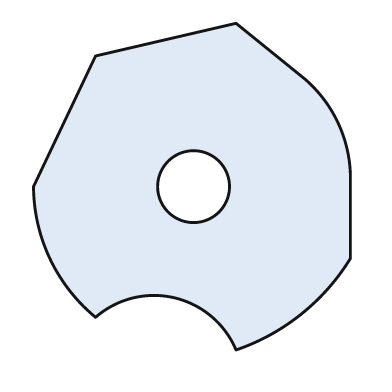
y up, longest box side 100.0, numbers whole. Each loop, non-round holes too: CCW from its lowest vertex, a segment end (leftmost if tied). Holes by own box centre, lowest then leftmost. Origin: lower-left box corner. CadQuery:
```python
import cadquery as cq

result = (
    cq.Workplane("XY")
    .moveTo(62.0, 0.0)
    .threePointArc((82.0, 11.0), (97.0, 28.0))
    .lineTo(97.0, 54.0)
    .threePointArc((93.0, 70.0), (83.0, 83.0))
    .lineTo(62.0, 100.0)
    .lineTo(19.0, 90.0)
    .lineTo(0.0, 50.0)
    .threePointArc((5.0, 28.0), (19.0, 10.0))
    .threePointArc((43.0, 16.0), (62.0, 0.0))
    .close()
    .moveTo(49.0, 50.0)
    .circle(11.0)
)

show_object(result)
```